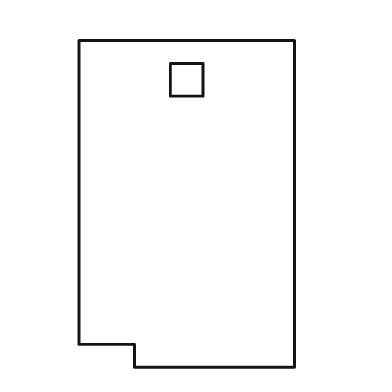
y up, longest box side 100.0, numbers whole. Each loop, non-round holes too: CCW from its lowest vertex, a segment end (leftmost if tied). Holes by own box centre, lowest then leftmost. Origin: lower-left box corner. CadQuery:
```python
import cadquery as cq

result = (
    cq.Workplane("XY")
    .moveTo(17.0, 0.0)
    .lineTo(66.0, 0.0)
    .lineTo(66.0, 100.0)
    .lineTo(0.0, 100.0)
    .lineTo(0.0, 7.0)
    .lineTo(17.0, 7.0)
    .close()
    .moveTo(28.0, 83.0)
    .lineTo(38.0, 83.0)
    .lineTo(38.0, 93.0)
    .lineTo(28.0, 93.0)
    .close()
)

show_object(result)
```